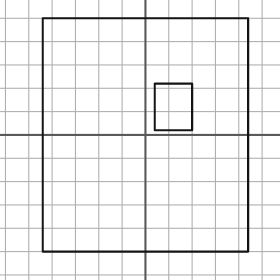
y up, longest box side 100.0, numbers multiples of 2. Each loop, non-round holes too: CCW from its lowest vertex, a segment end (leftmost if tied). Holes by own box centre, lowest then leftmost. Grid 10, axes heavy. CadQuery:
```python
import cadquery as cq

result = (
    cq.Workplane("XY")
    .moveTo(-44.0, -50.0)
    .lineTo(44.0, -50.0)
    .lineTo(44.0, 50.0)
    .lineTo(-44.0, 50.0)
    .close()
    .moveTo(4.0, 2.0)
    .lineTo(20.0, 2.0)
    .lineTo(20.0, 22.0)
    .lineTo(4.0, 22.0)
    .close()
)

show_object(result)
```